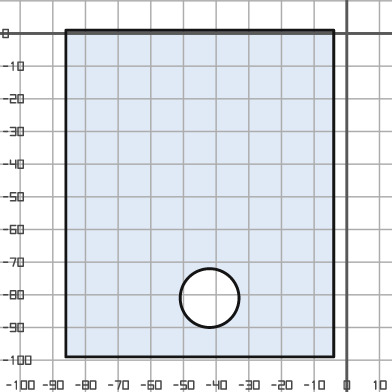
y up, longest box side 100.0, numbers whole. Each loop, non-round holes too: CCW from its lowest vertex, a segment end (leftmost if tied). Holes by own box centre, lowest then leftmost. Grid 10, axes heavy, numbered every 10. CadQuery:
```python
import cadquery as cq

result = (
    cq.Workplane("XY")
    .moveTo(-86.0, -99.0)
    .lineTo(-4.0, -99.0)
    .lineTo(-4.0, 1.0)
    .lineTo(-86.0, 1.0)
    .close()
    .moveTo(-42.0, -81.0)
    .circle(9.0)
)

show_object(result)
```